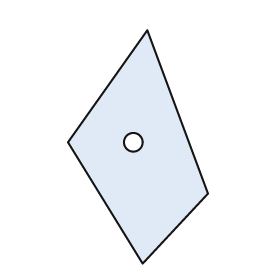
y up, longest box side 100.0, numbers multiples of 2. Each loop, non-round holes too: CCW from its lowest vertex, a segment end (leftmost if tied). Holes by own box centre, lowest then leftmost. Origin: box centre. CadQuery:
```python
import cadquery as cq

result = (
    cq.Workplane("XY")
    .moveTo(2.0, -50.0)
    .lineTo(30.0, -20.0)
    .lineTo(4.0, 50.0)
    .lineTo(-30.0, 2.0)
    .close()
    .moveTo(-2.0, 2.0)
    .circle(4.0)
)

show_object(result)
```